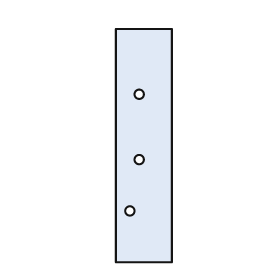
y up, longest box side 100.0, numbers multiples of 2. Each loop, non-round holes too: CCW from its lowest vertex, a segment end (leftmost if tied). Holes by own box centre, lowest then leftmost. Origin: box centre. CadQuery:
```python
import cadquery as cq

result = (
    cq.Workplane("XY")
    .moveTo(-12.0, -50.0)
    .lineTo(12.0, -50.0)
    .lineTo(12.0, 50.0)
    .lineTo(-12.0, 50.0)
    .close()
    .moveTo(-6.0, -28.0)
    .circle(2.0)
    .moveTo(-2.0, -6.0)
    .circle(2.0)
    .moveTo(-2.0, 22.0)
    .circle(2.0)
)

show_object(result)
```